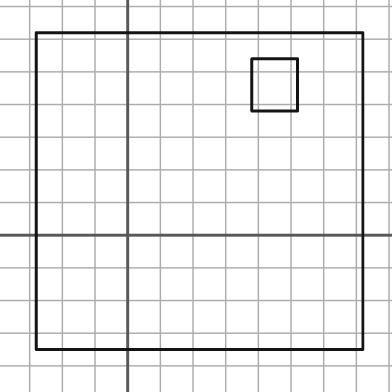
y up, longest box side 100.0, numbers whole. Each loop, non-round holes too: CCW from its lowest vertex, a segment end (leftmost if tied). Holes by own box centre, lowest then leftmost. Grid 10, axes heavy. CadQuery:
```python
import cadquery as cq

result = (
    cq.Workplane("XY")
    .moveTo(-28.0, -35.0)
    .lineTo(72.0, -35.0)
    .lineTo(72.0, 62.0)
    .lineTo(-28.0, 62.0)
    .close()
    .moveTo(38.0, 38.0)
    .lineTo(52.0, 38.0)
    .lineTo(52.0, 54.0)
    .lineTo(38.0, 54.0)
    .close()
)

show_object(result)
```